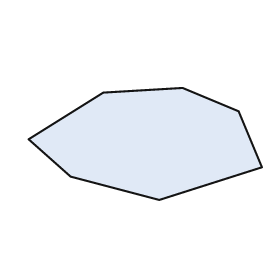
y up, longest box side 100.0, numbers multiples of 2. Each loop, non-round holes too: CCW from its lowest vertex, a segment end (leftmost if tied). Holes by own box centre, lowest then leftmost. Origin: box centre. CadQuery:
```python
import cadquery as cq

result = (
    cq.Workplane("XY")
    .moveTo(6.0, -24.0)
    .lineTo(50.0, -10.0)
    .lineTo(40.0, 14.0)
    .lineTo(16.0, 24.0)
    .lineTo(-18.0, 22.0)
    .lineTo(-50.0, 2.0)
    .lineTo(-32.0, -14.0)
    .close()
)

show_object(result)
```